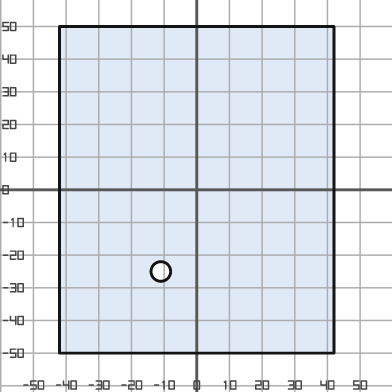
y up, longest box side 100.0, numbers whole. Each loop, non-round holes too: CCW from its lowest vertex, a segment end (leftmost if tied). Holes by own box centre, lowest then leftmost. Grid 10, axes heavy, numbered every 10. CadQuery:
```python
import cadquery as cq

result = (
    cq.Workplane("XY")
    .moveTo(-42.0, -50.0)
    .lineTo(42.0, -50.0)
    .lineTo(42.0, 50.0)
    .lineTo(-42.0, 50.0)
    .close()
    .moveTo(-11.0, -25.0)
    .circle(3.0)
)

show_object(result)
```